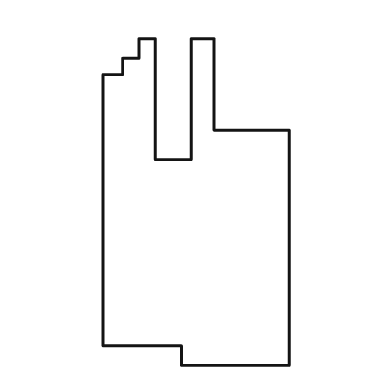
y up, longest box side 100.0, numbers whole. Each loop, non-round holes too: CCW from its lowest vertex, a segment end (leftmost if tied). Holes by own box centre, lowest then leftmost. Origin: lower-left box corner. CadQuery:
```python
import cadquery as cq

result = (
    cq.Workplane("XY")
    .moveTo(24.0, 0.0)
    .lineTo(57.0, 0.0)
    .lineTo(57.0, 72.0)
    .lineTo(34.0, 72.0)
    .lineTo(34.0, 100.0)
    .lineTo(27.0, 100.0)
    .lineTo(27.0, 63.0)
    .lineTo(16.0, 63.0)
    .lineTo(16.0, 100.0)
    .lineTo(11.0, 100.0)
    .lineTo(11.0, 94.0)
    .lineTo(6.0, 94.0)
    .lineTo(6.0, 89.0)
    .lineTo(0.0, 89.0)
    .lineTo(0.0, 6.0)
    .lineTo(24.0, 6.0)
    .close()
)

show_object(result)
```